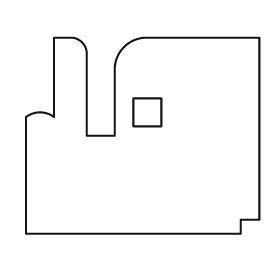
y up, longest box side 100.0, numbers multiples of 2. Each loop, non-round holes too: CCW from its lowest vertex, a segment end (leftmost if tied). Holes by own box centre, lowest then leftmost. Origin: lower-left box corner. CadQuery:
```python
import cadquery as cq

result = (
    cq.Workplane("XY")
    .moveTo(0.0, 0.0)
    .lineTo(92.0, 0.0)
    .lineTo(92.0, 6.0)
    .lineTo(100.0, 6.0)
    .lineTo(100.0, 84.0)
    .lineTo(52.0, 84.0)
    .threePointArc((42.0, 80.0), (38.0, 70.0))
    .lineTo(38.0, 42.0)
    .lineTo(26.0, 42.0)
    .lineTo(26.0, 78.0)
    .threePointArc((24.0, 82.0), (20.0, 84.0))
    .lineTo(12.0, 84.0)
    .lineTo(12.0, 50.0)
    .threePointArc((6.0, 52.0), (0.0, 50.0))
    .close()
    .moveTo(46.0, 46.0)
    .lineTo(58.0, 46.0)
    .lineTo(58.0, 58.0)
    .lineTo(46.0, 58.0)
    .close()
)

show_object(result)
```